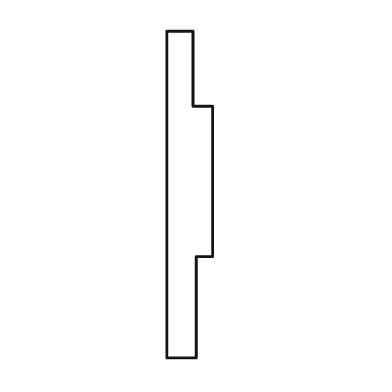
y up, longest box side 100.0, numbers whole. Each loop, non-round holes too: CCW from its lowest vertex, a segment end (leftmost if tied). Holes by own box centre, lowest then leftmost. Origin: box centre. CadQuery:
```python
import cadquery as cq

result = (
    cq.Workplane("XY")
    .moveTo(-7.0, -50.0)
    .lineTo(2.0, -50.0)
    .lineTo(2.0, -19.0)
    .lineTo(7.0, -19.0)
    .lineTo(7.0, 27.0)
    .lineTo(1.0, 27.0)
    .lineTo(1.0, 50.0)
    .lineTo(-7.0, 50.0)
    .close()
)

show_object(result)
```